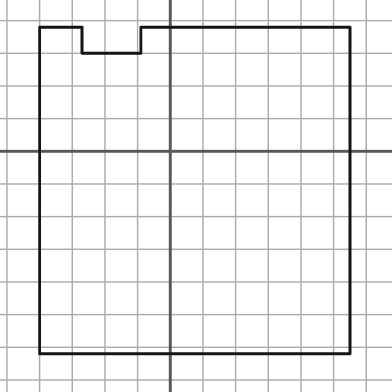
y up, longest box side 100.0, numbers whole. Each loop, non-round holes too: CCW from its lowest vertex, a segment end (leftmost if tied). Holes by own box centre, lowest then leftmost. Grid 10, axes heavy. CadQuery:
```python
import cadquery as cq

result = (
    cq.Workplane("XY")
    .moveTo(-40.0, -62.0)
    .lineTo(55.0, -62.0)
    .lineTo(55.0, 38.0)
    .lineTo(-9.0, 38.0)
    .lineTo(-9.0, 30.0)
    .lineTo(-27.0, 30.0)
    .lineTo(-27.0, 38.0)
    .lineTo(-40.0, 38.0)
    .close()
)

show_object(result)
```